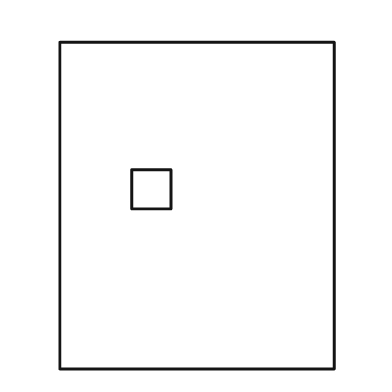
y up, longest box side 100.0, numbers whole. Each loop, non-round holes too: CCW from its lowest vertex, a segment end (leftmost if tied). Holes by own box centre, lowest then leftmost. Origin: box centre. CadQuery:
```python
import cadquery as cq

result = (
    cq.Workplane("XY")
    .moveTo(-42.0, -50.0)
    .lineTo(42.0, -50.0)
    .lineTo(42.0, 50.0)
    .lineTo(-42.0, 50.0)
    .close()
    .moveTo(-20.0, -1.0)
    .lineTo(-8.0, -1.0)
    .lineTo(-8.0, 11.0)
    .lineTo(-20.0, 11.0)
    .close()
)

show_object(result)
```